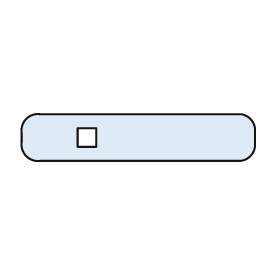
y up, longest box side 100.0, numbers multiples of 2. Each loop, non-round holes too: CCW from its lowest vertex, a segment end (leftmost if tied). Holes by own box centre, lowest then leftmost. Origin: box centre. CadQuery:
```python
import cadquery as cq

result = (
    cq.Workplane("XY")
    .moveTo(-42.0, -10.0)
    .lineTo(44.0, -10.0)
    .threePointArc((48.0, -8.0), (50.0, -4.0))
    .lineTo(50.0, 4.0)
    .threePointArc((48.0, 8.0), (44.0, 10.0))
    .lineTo(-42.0, 10.0)
    .threePointArc((-48.0, 8.0), (-50.0, 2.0))
    .lineTo(-50.0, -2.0)
    .threePointArc((-48.0, -8.0), (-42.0, -10.0))
    .close()
    .moveTo(-26.0, -4.0)
    .lineTo(-18.0, -4.0)
    .lineTo(-18.0, 4.0)
    .lineTo(-26.0, 4.0)
    .close()
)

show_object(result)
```